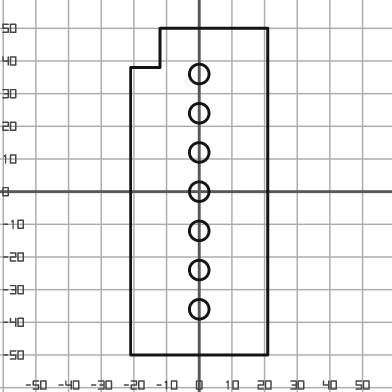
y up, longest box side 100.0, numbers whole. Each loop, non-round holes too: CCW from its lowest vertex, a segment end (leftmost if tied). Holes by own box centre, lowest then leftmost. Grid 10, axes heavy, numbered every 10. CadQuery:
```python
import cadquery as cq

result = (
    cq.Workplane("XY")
    .moveTo(-21.0, -50.0)
    .lineTo(21.0, -50.0)
    .lineTo(21.0, 50.0)
    .lineTo(-12.0, 50.0)
    .lineTo(-12.0, 38.0)
    .lineTo(-21.0, 38.0)
    .close()
    .moveTo(0.0, -36.0)
    .circle(3.0)
    .moveTo(0.0, -24.0)
    .circle(3.0)
    .moveTo(0.0, -12.0)
    .circle(3.0)
    .moveTo(0.0, 0.0)
    .circle(3.0)
    .moveTo(0.0, 12.0)
    .circle(3.0)
    .moveTo(0.0, 24.0)
    .circle(3.0)
    .moveTo(0.0, 36.0)
    .circle(3.0)
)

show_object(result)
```